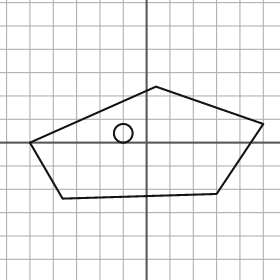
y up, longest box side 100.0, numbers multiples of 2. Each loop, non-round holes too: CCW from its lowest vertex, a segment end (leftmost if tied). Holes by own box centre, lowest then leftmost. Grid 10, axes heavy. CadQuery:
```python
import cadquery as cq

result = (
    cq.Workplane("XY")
    .moveTo(-36.0, -24.0)
    .lineTo(30.0, -22.0)
    .lineTo(50.0, 8.0)
    .lineTo(4.0, 24.0)
    .lineTo(-50.0, 0.0)
    .close()
    .moveTo(-10.0, 4.0)
    .circle(4.0)
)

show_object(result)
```